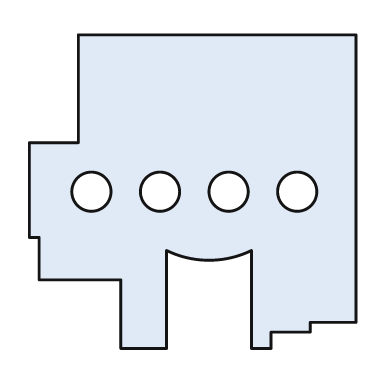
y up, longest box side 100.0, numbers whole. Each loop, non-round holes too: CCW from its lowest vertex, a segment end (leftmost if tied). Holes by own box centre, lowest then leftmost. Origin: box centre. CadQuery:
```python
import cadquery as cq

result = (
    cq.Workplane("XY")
    .moveTo(-22.0, -48.0)
    .lineTo(-8.0, -48.0)
    .lineTo(-8.0, -18.0)
    .threePointArc((5.0, -21.0), (18.0, -18.0))
    .lineTo(18.0, -48.0)
    .lineTo(24.0, -48.0)
    .lineTo(24.0, -43.0)
    .lineTo(36.0, -43.0)
    .lineTo(36.0, -40.0)
    .lineTo(50.0, -40.0)
    .lineTo(50.0, 48.0)
    .lineTo(-35.0, 48.0)
    .lineTo(-35.0, 15.0)
    .lineTo(-50.0, 15.0)
    .lineTo(-50.0, -14.0)
    .lineTo(-47.0, -14.0)
    .lineTo(-47.0, -27.0)
    .lineTo(-22.0, -27.0)
    .close()
    .moveTo(-31.0, 0.0)
    .circle(6.0)
    .moveTo(-10.0, 0.0)
    .circle(6.0)
    .moveTo(11.0, 0.0)
    .circle(6.0)
    .moveTo(32.0, 0.0)
    .circle(6.0)
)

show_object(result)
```